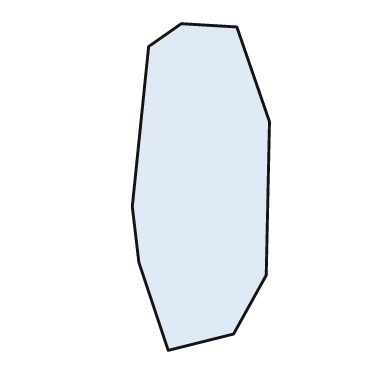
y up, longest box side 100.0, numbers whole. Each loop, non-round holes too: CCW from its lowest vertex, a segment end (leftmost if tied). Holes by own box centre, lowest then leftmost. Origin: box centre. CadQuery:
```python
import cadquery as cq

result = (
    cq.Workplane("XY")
    .moveTo(-10.0, -50.0)
    .lineTo(10.0, -45.0)
    .lineTo(20.0, -27.0)
    .lineTo(21.0, 20.0)
    .lineTo(11.0, 49.0)
    .lineTo(-6.0, 50.0)
    .lineTo(-16.0, 43.0)
    .lineTo(-21.0, -6.0)
    .lineTo(-19.0, -23.0)
    .close()
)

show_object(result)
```